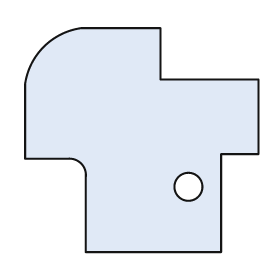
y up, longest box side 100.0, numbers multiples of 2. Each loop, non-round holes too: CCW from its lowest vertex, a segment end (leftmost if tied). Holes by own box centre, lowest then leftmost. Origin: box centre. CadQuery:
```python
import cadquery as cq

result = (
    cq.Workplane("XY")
    .moveTo(-24.0, -48.0)
    .lineTo(34.0, -48.0)
    .lineTo(34.0, -6.0)
    .lineTo(50.0, -6.0)
    .lineTo(50.0, 26.0)
    .lineTo(8.0, 26.0)
    .lineTo(8.0, 48.0)
    .lineTo(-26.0, 48.0)
    .threePointArc((-42.0, 40.0), (-50.0, 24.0))
    .lineTo(-50.0, -8.0)
    .lineTo(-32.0, -8.0)
    .threePointArc((-26.0, -10.0), (-24.0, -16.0))
    .close()
    .moveTo(20.0, -20.0)
    .circle(6.0)
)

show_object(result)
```